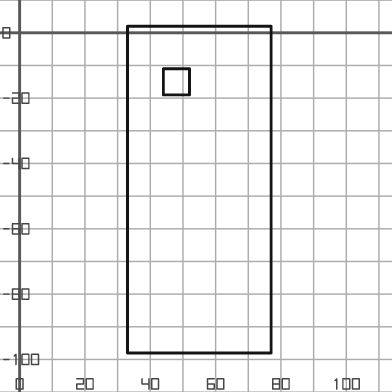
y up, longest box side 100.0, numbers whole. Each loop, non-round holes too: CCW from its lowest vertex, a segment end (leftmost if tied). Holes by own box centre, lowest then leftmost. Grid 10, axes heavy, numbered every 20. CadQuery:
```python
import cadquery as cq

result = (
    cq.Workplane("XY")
    .moveTo(33.0, -98.0)
    .lineTo(77.0, -98.0)
    .lineTo(77.0, 2.0)
    .lineTo(33.0, 2.0)
    .close()
    .moveTo(44.0, -19.0)
    .lineTo(52.0, -19.0)
    .lineTo(52.0, -11.0)
    .lineTo(44.0, -11.0)
    .close()
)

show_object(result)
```